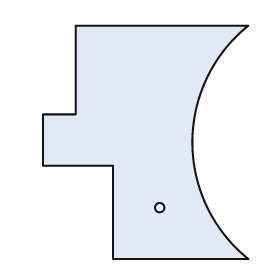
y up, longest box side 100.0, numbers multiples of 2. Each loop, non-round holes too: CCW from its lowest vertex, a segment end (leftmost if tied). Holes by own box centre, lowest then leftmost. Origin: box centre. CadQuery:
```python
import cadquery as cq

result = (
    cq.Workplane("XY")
    .moveTo(-14.0, -50.0)
    .lineTo(44.0, -50.0)
    .threePointArc((20.0, 0.0), (44.0, 50.0))
    .lineTo(-30.0, 50.0)
    .lineTo(-30.0, 12.0)
    .lineTo(-44.0, 12.0)
    .lineTo(-44.0, -10.0)
    .lineTo(-14.0, -10.0)
    .close()
    .moveTo(6.0, -28.0)
    .circle(2.0)
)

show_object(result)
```